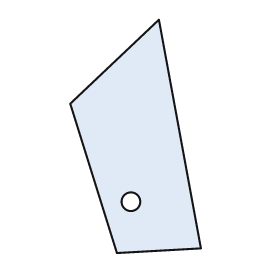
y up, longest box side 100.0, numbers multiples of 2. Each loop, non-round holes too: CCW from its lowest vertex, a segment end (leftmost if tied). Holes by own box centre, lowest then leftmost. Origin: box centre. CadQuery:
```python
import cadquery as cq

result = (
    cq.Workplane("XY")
    .moveTo(-8.0, -50.0)
    .lineTo(28.0, -48.0)
    .lineTo(10.0, 50.0)
    .lineTo(-28.0, 14.0)
    .close()
    .moveTo(-2.0, -28.0)
    .circle(4.0)
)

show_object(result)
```